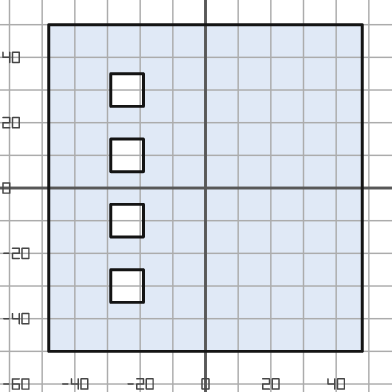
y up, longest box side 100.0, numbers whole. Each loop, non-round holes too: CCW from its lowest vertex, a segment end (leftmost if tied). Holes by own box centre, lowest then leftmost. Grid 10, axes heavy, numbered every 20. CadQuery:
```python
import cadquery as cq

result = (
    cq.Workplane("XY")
    .moveTo(-48.0, -50.0)
    .lineTo(48.0, -50.0)
    .lineTo(48.0, 50.0)
    .lineTo(-48.0, 50.0)
    .close()
    .moveTo(-29.0, -35.0)
    .lineTo(-19.0, -35.0)
    .lineTo(-19.0, -25.0)
    .lineTo(-29.0, -25.0)
    .close()
    .moveTo(-29.0, -15.0)
    .lineTo(-19.0, -15.0)
    .lineTo(-19.0, -5.0)
    .lineTo(-29.0, -5.0)
    .close()
    .moveTo(-29.0, 5.0)
    .lineTo(-19.0, 5.0)
    .lineTo(-19.0, 15.0)
    .lineTo(-29.0, 15.0)
    .close()
    .moveTo(-29.0, 25.0)
    .lineTo(-19.0, 25.0)
    .lineTo(-19.0, 35.0)
    .lineTo(-29.0, 35.0)
    .close()
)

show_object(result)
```